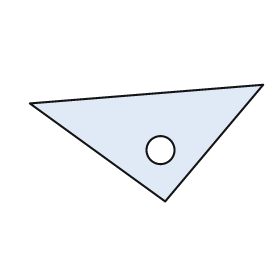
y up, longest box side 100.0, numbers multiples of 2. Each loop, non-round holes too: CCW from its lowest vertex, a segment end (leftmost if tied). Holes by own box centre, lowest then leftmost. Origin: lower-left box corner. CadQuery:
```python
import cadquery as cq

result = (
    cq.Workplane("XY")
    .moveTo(58.0, 0.0)
    .lineTo(100.0, 50.0)
    .lineTo(0.0, 42.0)
    .close()
    .moveTo(56.0, 22.0)
    .circle(6.0)
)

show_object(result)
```